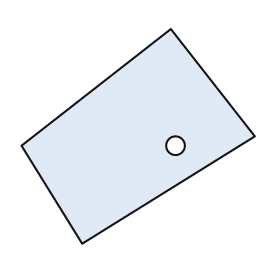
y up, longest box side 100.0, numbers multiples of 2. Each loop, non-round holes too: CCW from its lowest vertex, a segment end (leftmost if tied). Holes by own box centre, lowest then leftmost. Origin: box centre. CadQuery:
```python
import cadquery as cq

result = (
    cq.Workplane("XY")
    .moveTo(-24.0, -46.0)
    .lineTo(50.0, 0.0)
    .lineTo(14.0, 46.0)
    .lineTo(-50.0, -4.0)
    .close()
    .moveTo(16.0, -4.0)
    .circle(4.0)
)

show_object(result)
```